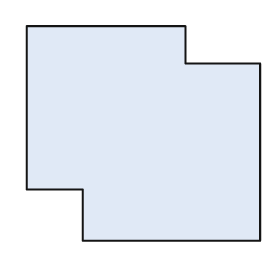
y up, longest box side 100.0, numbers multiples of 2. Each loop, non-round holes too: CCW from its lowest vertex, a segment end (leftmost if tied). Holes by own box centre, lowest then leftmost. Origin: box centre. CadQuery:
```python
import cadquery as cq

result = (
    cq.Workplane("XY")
    .moveTo(-26.0, -46.0)
    .lineTo(50.0, -46.0)
    .lineTo(50.0, 30.0)
    .lineTo(18.0, 30.0)
    .lineTo(18.0, 46.0)
    .lineTo(-50.0, 46.0)
    .lineTo(-50.0, -24.0)
    .lineTo(-26.0, -24.0)
    .close()
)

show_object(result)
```